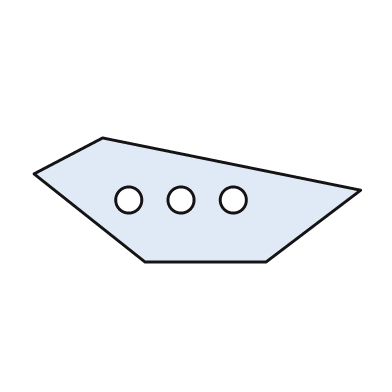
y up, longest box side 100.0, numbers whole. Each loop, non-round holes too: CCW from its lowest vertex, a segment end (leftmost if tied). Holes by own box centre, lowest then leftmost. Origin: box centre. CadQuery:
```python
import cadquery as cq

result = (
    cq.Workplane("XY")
    .moveTo(-16.0, -19.0)
    .lineTo(21.0, -19.0)
    .lineTo(50.0, 3.0)
    .lineTo(-29.0, 19.0)
    .lineTo(-50.0, 8.0)
    .close()
    .moveTo(-21.0, 0.0)
    .circle(4.0)
    .moveTo(-5.0, 0.0)
    .circle(4.0)
    .moveTo(11.0, 0.0)
    .circle(4.0)
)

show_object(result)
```